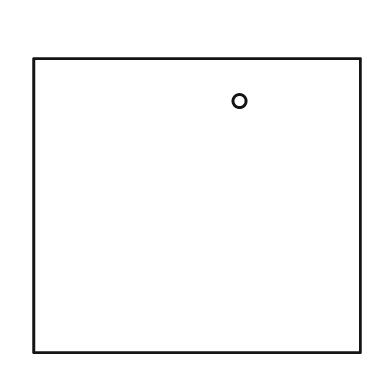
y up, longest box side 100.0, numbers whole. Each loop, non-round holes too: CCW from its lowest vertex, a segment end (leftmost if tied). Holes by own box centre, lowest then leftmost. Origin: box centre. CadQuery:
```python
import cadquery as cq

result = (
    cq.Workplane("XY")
    .moveTo(-50.0, -45.0)
    .lineTo(50.0, -45.0)
    .lineTo(50.0, 45.0)
    .lineTo(-50.0, 45.0)
    .close()
    .moveTo(13.0, 32.0)
    .circle(2.0)
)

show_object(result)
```